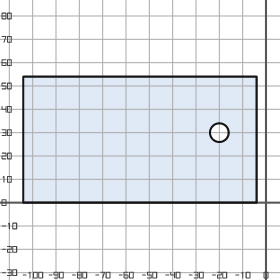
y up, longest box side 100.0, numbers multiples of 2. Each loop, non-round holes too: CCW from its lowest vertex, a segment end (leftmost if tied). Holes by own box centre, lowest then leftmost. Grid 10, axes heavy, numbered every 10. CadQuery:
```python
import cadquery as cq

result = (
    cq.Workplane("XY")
    .moveTo(-104.0, 0.0)
    .lineTo(-4.0, 0.0)
    .lineTo(-4.0, 54.0)
    .lineTo(-104.0, 54.0)
    .close()
    .moveTo(-20.0, 30.0)
    .circle(4.0)
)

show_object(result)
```